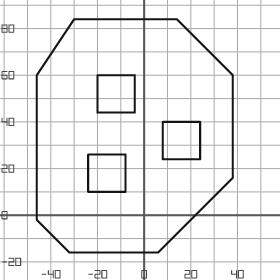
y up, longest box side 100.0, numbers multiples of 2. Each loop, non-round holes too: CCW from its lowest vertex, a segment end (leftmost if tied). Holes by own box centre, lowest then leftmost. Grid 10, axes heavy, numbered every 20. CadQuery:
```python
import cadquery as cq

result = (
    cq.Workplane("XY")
    .moveTo(-32.0, -16.0)
    .lineTo(6.0, -16.0)
    .lineTo(38.0, 16.0)
    .lineTo(38.0, 60.0)
    .lineTo(14.0, 84.0)
    .lineTo(-30.0, 84.0)
    .lineTo(-46.0, 60.0)
    .lineTo(-46.0, -2.0)
    .close()
    .moveTo(-24.0, 10.0)
    .lineTo(-8.0, 10.0)
    .lineTo(-8.0, 26.0)
    .lineTo(-24.0, 26.0)
    .close()
    .moveTo(8.0, 24.0)
    .lineTo(24.0, 24.0)
    .lineTo(24.0, 40.0)
    .lineTo(8.0, 40.0)
    .close()
    .moveTo(-20.0, 44.0)
    .lineTo(-4.0, 44.0)
    .lineTo(-4.0, 60.0)
    .lineTo(-20.0, 60.0)
    .close()
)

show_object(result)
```